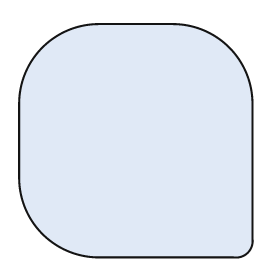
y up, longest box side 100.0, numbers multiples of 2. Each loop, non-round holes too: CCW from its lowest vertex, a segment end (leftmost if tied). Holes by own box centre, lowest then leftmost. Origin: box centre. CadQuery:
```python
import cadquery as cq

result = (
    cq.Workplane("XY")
    .moveTo(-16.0, -50.0)
    .lineTo(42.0, -50.0)
    .threePointArc((48.0, -48.0), (50.0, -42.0))
    .lineTo(50.0, 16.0)
    .threePointArc((40.0, 40.0), (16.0, 50.0))
    .lineTo(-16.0, 50.0)
    .threePointArc((-40.0, 40.0), (-50.0, 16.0))
    .lineTo(-50.0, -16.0)
    .threePointArc((-40.0, -40.0), (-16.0, -50.0))
    .close()
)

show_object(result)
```